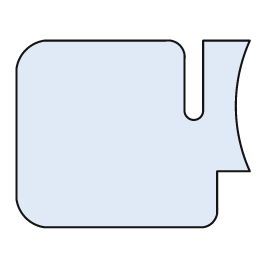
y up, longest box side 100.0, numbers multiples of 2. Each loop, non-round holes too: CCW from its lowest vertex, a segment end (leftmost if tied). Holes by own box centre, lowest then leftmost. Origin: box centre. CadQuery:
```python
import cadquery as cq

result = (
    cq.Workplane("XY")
    .moveTo(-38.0, -40.0)
    .lineTo(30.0, -40.0)
    .threePointArc((34.0, -38.0), (36.0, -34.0))
    .lineTo(36.0, -16.0)
    .lineTo(50.0, -16.0)
    .threePointArc((44.0, 12.0), (50.0, 40.0))
    .lineTo(30.0, 40.0)
    .lineTo(30.0, 10.0)
    .threePointArc((26.0, 6.0), (22.0, 10.0))
    .lineTo(22.0, 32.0)
    .threePointArc((20.0, 38.0), (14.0, 40.0))
    .lineTo(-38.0, 40.0)
    .threePointArc((-46.0, 36.0), (-50.0, 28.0))
    .lineTo(-50.0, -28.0)
    .threePointArc((-46.0, -36.0), (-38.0, -40.0))
    .close()
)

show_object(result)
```